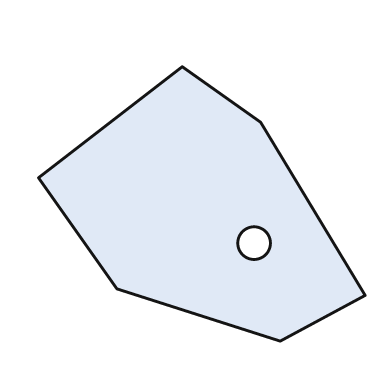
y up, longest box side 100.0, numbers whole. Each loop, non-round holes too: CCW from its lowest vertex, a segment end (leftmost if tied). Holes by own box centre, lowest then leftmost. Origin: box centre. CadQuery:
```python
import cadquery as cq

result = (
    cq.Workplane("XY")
    .moveTo(24.0, -42.0)
    .lineTo(50.0, -28.0)
    .lineTo(18.0, 25.0)
    .lineTo(-6.0, 42.0)
    .lineTo(-50.0, 8.0)
    .lineTo(-26.0, -26.0)
    .close()
    .moveTo(16.0, -12.0)
    .circle(5.0)
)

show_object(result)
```